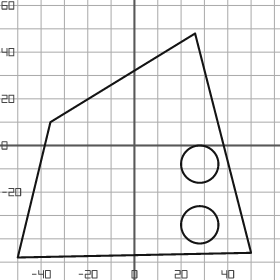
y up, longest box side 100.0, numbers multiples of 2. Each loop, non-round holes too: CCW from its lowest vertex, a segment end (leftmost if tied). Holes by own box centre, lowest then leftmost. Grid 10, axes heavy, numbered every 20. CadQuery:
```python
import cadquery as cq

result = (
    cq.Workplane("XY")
    .moveTo(-50.0, -48.0)
    .lineTo(50.0, -46.0)
    .lineTo(26.0, 48.0)
    .lineTo(-36.0, 10.0)
    .close()
    .moveTo(28.0, -34.0)
    .circle(8.0)
    .moveTo(28.0, -8.0)
    .circle(8.0)
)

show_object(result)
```